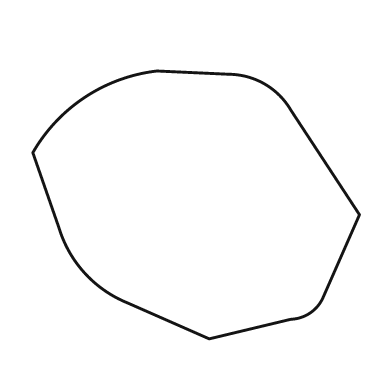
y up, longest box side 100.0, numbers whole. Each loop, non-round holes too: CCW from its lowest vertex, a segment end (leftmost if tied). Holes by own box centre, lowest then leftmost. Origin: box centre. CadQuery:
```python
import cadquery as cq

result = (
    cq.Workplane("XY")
    .moveTo(4.0, -41.0)
    .lineTo(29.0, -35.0)
    .threePointArc((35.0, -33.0), (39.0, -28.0))
    .lineTo(50.0, -3.0)
    .lineTo(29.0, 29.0)
    .threePointArc((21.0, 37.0), (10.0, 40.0))
    .lineTo(-12.0, 41.0)
    .threePointArc((-34.0, 33.0), (-50.0, 16.0))
    .lineTo(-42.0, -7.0)
    .threePointArc((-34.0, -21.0), (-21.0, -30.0))
    .close()
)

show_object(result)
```